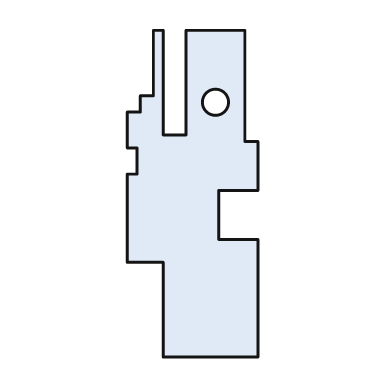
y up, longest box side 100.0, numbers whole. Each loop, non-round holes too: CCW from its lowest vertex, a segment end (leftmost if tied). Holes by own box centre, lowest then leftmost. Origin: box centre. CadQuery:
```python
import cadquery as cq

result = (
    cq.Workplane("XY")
    .moveTo(-9.0, -50.0)
    .lineTo(20.0, -50.0)
    .lineTo(20.0, -14.0)
    .lineTo(8.0, -14.0)
    .lineTo(8.0, 1.0)
    .lineTo(20.0, 1.0)
    .lineTo(20.0, 16.0)
    .lineTo(16.0, 16.0)
    .lineTo(16.0, 50.0)
    .lineTo(-2.0, 50.0)
    .lineTo(-2.0, 18.0)
    .lineTo(-9.0, 18.0)
    .lineTo(-9.0, 50.0)
    .lineTo(-12.0, 50.0)
    .lineTo(-12.0, 30.0)
    .lineTo(-16.0, 30.0)
    .lineTo(-16.0, 25.0)
    .lineTo(-20.0, 25.0)
    .lineTo(-20.0, 14.0)
    .lineTo(-17.0, 14.0)
    .lineTo(-17.0, 6.0)
    .lineTo(-20.0, 6.0)
    .lineTo(-20.0, -21.0)
    .lineTo(-9.0, -21.0)
    .close()
    .moveTo(7.0, 28.0)
    .circle(4.0)
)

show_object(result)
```